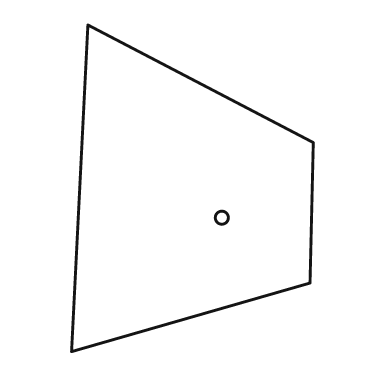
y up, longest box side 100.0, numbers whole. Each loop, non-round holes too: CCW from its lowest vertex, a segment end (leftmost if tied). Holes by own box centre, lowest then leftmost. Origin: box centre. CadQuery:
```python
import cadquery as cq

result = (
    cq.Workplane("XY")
    .moveTo(-37.0, -50.0)
    .lineTo(36.0, -29.0)
    .lineTo(37.0, 14.0)
    .lineTo(-32.0, 50.0)
    .close()
    .moveTo(9.0, -9.0)
    .circle(2.0)
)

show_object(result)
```